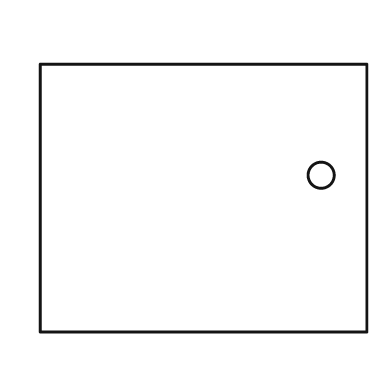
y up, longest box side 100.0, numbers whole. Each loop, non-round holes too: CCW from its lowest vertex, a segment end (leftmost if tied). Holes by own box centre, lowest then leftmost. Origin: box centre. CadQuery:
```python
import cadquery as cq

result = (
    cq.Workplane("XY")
    .moveTo(-50.0, -41.0)
    .lineTo(50.0, -41.0)
    .lineTo(50.0, 41.0)
    .lineTo(-50.0, 41.0)
    .close()
    .moveTo(36.0, 7.0)
    .circle(4.0)
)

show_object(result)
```